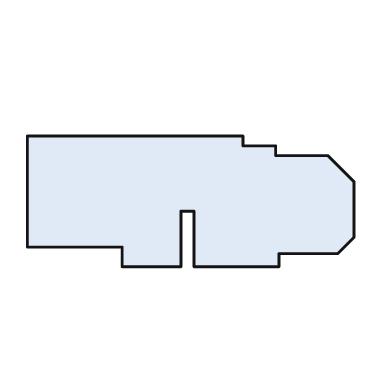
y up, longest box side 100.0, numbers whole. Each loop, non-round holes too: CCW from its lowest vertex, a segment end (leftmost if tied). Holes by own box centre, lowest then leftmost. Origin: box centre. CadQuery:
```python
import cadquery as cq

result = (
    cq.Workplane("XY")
    .moveTo(-21.0, -20.0)
    .lineTo(-3.0, -20.0)
    .lineTo(-3.0, -3.0)
    .lineTo(1.0, -3.0)
    .lineTo(1.0, -20.0)
    .lineTo(27.0, -20.0)
    .lineTo(27.0, -16.0)
    .lineTo(45.0, -16.0)
    .lineTo(50.0, -11.0)
    .lineTo(50.0, 6.0)
    .lineTo(42.0, 14.0)
    .lineTo(26.0, 14.0)
    .lineTo(26.0, 17.0)
    .lineTo(16.0, 17.0)
    .lineTo(16.0, 20.0)
    .lineTo(-50.0, 20.0)
    .lineTo(-50.0, -14.0)
    .lineTo(-21.0, -14.0)
    .close()
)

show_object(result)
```